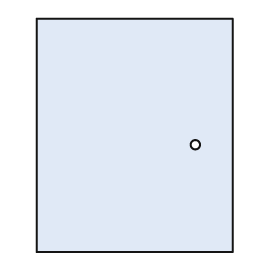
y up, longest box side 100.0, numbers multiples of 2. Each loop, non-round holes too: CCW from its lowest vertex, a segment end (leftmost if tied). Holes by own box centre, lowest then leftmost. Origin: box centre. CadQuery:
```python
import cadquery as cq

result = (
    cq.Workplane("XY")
    .moveTo(-42.0, -50.0)
    .lineTo(42.0, -50.0)
    .lineTo(42.0, 50.0)
    .lineTo(-42.0, 50.0)
    .close()
    .moveTo(26.0, -4.0)
    .circle(2.0)
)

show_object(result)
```